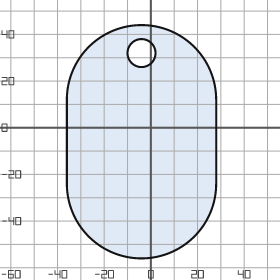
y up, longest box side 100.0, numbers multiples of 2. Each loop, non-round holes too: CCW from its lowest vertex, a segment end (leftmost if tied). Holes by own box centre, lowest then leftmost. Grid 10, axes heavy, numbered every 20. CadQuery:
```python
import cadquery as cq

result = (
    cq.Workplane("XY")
    .moveTo(-36.0, -24.0)
    .threePointArc((-4.0, -56.0), (28.0, -24.0))
    .lineTo(28.0, 12.0)
    .threePointArc((-4.0, 44.0), (-36.0, 12.0))
    .close()
    .moveTo(-4.0, 32.0)
    .circle(6.0)
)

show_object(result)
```